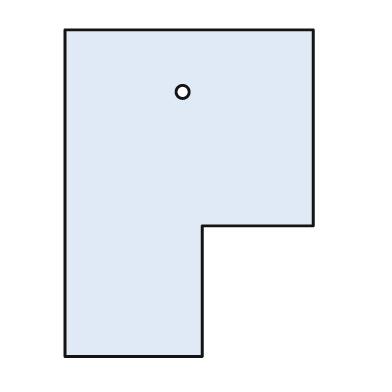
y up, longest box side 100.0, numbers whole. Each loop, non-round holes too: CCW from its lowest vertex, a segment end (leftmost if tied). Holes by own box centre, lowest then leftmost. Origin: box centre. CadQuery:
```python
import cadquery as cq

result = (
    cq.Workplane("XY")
    .moveTo(-38.0, -50.0)
    .lineTo(4.0, -50.0)
    .lineTo(4.0, -10.0)
    .lineTo(38.0, -10.0)
    .lineTo(38.0, 50.0)
    .lineTo(-38.0, 50.0)
    .close()
    .moveTo(-2.0, 31.0)
    .circle(2.0)
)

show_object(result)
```